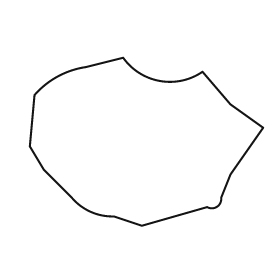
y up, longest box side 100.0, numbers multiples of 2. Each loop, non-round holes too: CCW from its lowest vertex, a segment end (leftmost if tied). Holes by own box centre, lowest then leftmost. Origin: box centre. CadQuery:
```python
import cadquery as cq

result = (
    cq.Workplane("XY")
    .moveTo(-2.0, -36.0)
    .lineTo(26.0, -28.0)
    .threePointArc((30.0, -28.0), (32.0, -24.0))
    .lineTo(36.0, -14.0)
    .lineTo(50.0, 6.0)
    .lineTo(36.0, 16.0)
    .lineTo(24.0, 30.0)
    .threePointArc((6.0, 26.0), (-10.0, 36.0))
    .lineTo(-26.0, 32.0)
    .threePointArc((-38.0, 28.0), (-48.0, 20.0))
    .lineTo(-50.0, -2.0)
    .lineTo(-44.0, -12.0)
    .lineTo(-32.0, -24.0)
    .threePointArc((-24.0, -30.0), (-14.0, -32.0))
    .close()
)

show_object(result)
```